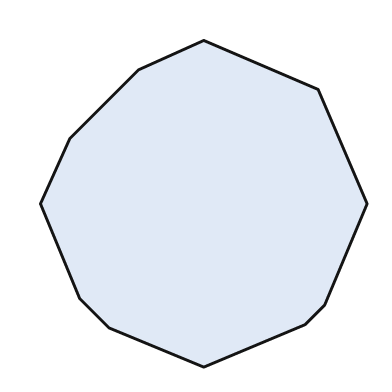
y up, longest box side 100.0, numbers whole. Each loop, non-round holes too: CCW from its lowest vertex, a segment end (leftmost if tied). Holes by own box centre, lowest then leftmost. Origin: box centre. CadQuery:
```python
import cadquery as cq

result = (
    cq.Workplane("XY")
    .moveTo(0.0, -50.0)
    .lineTo(31.0, -37.0)
    .lineTo(37.0, -31.0)
    .lineTo(50.0, 0.0)
    .lineTo(35.0, 35.0)
    .lineTo(0.0, 50.0)
    .lineTo(-20.0, 41.0)
    .lineTo(-41.0, 20.0)
    .lineTo(-50.0, 0.0)
    .lineTo(-38.0, -29.0)
    .lineTo(-29.0, -38.0)
    .close()
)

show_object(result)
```